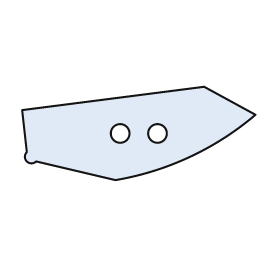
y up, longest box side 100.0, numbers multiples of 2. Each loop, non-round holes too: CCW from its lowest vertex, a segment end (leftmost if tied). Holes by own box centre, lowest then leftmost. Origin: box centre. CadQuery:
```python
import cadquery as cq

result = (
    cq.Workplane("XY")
    .moveTo(-10.0, -20.0)
    .threePointArc((22.0, -10.0), (50.0, 8.0))
    .lineTo(28.0, 20.0)
    .lineTo(-50.0, 10.0)
    .lineTo(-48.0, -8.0)
    .threePointArc((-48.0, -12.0), (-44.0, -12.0))
    .close()
    .moveTo(-8.0, 0.0)
    .circle(4.0)
    .moveTo(8.0, 0.0)
    .circle(4.0)
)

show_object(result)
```